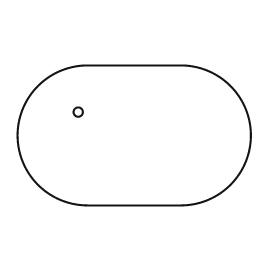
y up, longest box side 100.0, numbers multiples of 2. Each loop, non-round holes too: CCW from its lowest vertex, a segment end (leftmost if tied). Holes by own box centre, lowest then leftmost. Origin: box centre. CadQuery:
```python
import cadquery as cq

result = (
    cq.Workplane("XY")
    .moveTo(-20.0, -30.0)
    .lineTo(20.0, -30.0)
    .threePointArc((50.0, 0.0), (20.0, 30.0))
    .lineTo(-20.0, 30.0)
    .threePointArc((-50.0, 0.0), (-20.0, -30.0))
    .close()
    .moveTo(-24.0, 10.0)
    .circle(2.0)
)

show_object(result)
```